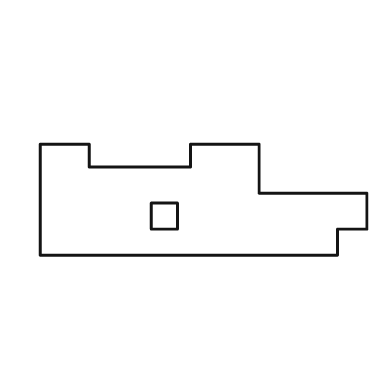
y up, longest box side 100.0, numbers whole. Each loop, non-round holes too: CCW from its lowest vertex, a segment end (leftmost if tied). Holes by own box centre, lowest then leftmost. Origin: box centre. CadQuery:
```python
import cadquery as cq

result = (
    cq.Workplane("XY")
    .moveTo(-50.0, -17.0)
    .lineTo(41.0, -17.0)
    .lineTo(41.0, -9.0)
    .lineTo(50.0, -9.0)
    .lineTo(50.0, 2.0)
    .lineTo(17.0, 2.0)
    .lineTo(17.0, 17.0)
    .lineTo(-4.0, 17.0)
    .lineTo(-4.0, 10.0)
    .lineTo(-35.0, 10.0)
    .lineTo(-35.0, 17.0)
    .lineTo(-50.0, 17.0)
    .close()
    .moveTo(-16.0, -9.0)
    .lineTo(-8.0, -9.0)
    .lineTo(-8.0, -1.0)
    .lineTo(-16.0, -1.0)
    .close()
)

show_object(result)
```